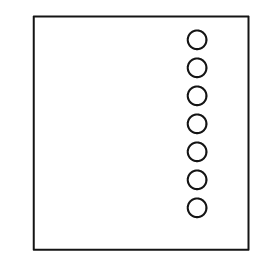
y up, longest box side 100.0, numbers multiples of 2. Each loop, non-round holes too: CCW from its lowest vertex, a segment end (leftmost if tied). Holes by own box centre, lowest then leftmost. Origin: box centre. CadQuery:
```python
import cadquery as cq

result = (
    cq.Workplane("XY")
    .moveTo(-46.0, -50.0)
    .lineTo(46.0, -50.0)
    .lineTo(46.0, 50.0)
    .lineTo(-46.0, 50.0)
    .close()
    .moveTo(24.0, -32.0)
    .circle(4.0)
    .moveTo(24.0, -20.0)
    .circle(4.0)
    .moveTo(24.0, -8.0)
    .circle(4.0)
    .moveTo(24.0, 4.0)
    .circle(4.0)
    .moveTo(24.0, 16.0)
    .circle(4.0)
    .moveTo(24.0, 28.0)
    .circle(4.0)
    .moveTo(24.0, 40.0)
    .circle(4.0)
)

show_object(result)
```